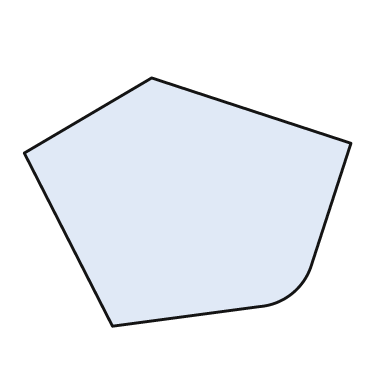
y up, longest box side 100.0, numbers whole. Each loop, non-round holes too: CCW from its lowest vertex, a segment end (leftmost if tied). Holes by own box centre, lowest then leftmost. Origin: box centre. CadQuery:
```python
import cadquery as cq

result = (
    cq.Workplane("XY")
    .moveTo(-23.0, -38.0)
    .lineTo(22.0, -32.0)
    .threePointArc((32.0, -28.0), (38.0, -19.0))
    .lineTo(50.0, 18.0)
    .lineTo(-11.0, 38.0)
    .lineTo(-50.0, 15.0)
    .close()
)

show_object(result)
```